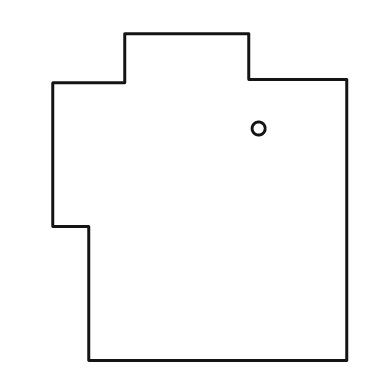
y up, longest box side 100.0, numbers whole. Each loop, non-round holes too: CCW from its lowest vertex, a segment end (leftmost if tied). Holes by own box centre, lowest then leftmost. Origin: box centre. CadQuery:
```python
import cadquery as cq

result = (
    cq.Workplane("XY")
    .moveTo(-34.0, -50.0)
    .lineTo(45.0, -50.0)
    .lineTo(45.0, 36.0)
    .lineTo(15.0, 36.0)
    .lineTo(15.0, 50.0)
    .lineTo(-23.0, 50.0)
    .lineTo(-23.0, 35.0)
    .lineTo(-45.0, 35.0)
    .lineTo(-45.0, -9.0)
    .lineTo(-34.0, -9.0)
    .close()
    .moveTo(18.0, 21.0)
    .circle(2.0)
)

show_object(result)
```